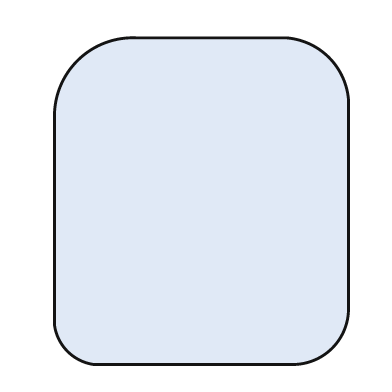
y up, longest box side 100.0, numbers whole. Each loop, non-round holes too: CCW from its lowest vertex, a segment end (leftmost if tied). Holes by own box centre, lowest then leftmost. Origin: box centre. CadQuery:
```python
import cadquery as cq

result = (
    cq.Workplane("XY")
    .moveTo(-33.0, -50.0)
    .lineTo(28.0, -50.0)
    .threePointArc((40.0, -45.0), (45.0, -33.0))
    .lineTo(45.0, 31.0)
    .threePointArc((39.0, 44.0), (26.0, 50.0))
    .lineTo(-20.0, 50.0)
    .threePointArc((-38.0, 43.0), (-45.0, 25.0))
    .lineTo(-45.0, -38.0)
    .threePointArc((-41.0, -46.0), (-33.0, -50.0))
    .close()
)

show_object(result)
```